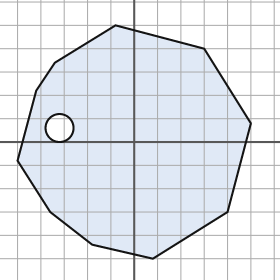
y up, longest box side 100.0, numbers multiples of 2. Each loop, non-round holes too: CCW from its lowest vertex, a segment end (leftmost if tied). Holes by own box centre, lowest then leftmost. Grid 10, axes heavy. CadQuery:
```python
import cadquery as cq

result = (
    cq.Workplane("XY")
    .moveTo(8.0, -50.0)
    .lineTo(40.0, -30.0)
    .lineTo(50.0, 8.0)
    .lineTo(30.0, 40.0)
    .lineTo(-8.0, 50.0)
    .lineTo(-34.0, 34.0)
    .lineTo(-42.0, 22.0)
    .lineTo(-50.0, -8.0)
    .lineTo(-36.0, -30.0)
    .lineTo(-18.0, -44.0)
    .close()
    .moveTo(-32.0, 6.0)
    .circle(6.0)
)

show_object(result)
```